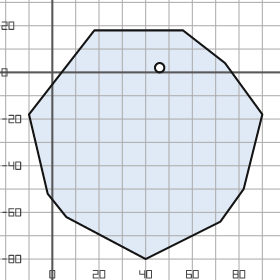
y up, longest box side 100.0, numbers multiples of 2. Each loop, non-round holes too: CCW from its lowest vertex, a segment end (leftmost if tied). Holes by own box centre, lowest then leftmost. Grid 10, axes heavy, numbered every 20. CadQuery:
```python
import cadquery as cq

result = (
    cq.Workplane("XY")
    .moveTo(40.0, -80.0)
    .lineTo(72.0, -64.0)
    .lineTo(82.0, -50.0)
    .lineTo(90.0, -18.0)
    .lineTo(74.0, 4.0)
    .lineTo(56.0, 18.0)
    .lineTo(18.0, 18.0)
    .lineTo(-10.0, -18.0)
    .lineTo(-2.0, -52.0)
    .lineTo(6.0, -62.0)
    .close()
    .moveTo(46.0, 2.0)
    .circle(2.0)
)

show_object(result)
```